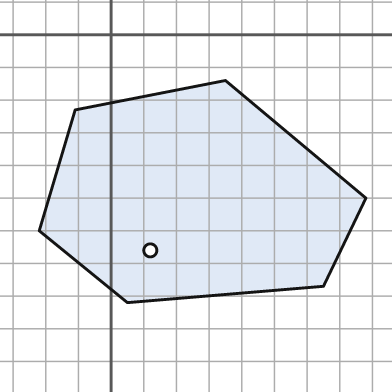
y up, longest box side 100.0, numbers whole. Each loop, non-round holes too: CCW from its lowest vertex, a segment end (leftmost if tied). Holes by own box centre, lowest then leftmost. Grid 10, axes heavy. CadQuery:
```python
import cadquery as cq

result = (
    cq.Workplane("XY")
    .moveTo(5.0, -82.0)
    .lineTo(65.0, -77.0)
    .lineTo(78.0, -50.0)
    .lineTo(35.0, -14.0)
    .lineTo(-11.0, -23.0)
    .lineTo(-22.0, -60.0)
    .close()
    .moveTo(12.0, -66.0)
    .circle(2.0)
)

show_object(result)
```